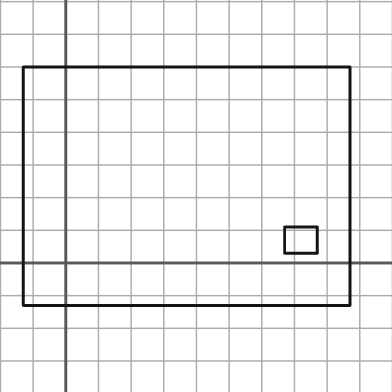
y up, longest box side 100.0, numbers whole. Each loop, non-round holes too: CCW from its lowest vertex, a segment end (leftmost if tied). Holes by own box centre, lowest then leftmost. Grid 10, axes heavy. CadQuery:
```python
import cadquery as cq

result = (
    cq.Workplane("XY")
    .moveTo(-13.0, -13.0)
    .lineTo(87.0, -13.0)
    .lineTo(87.0, 60.0)
    .lineTo(-13.0, 60.0)
    .close()
    .moveTo(67.0, 3.0)
    .lineTo(77.0, 3.0)
    .lineTo(77.0, 11.0)
    .lineTo(67.0, 11.0)
    .close()
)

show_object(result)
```